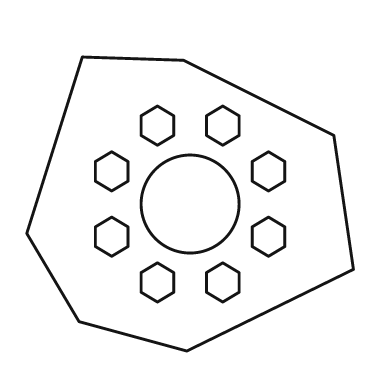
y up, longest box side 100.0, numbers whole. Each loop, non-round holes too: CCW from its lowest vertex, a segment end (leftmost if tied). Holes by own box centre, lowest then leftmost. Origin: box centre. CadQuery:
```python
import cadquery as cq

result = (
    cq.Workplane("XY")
    .moveTo(-1.0, -45.0)
    .lineTo(50.0, -20.0)
    .lineTo(44.0, 21.0)
    .lineTo(-2.0, 44.0)
    .lineTo(-33.0, 45.0)
    .lineTo(-50.0, -9.0)
    .lineTo(-34.0, -36.0)
    .close()
    .moveTo(-10.0, -30.0)
    .lineTo(-5.0, -27.0)
    .lineTo(-5.0, -21.0)
    .lineTo(-10.0, -18.0)
    .lineTo(-15.0, -21.0)
    .lineTo(-15.0, -27.0)
    .close()
    .moveTo(10.0, -30.0)
    .lineTo(15.0, -27.0)
    .lineTo(15.0, -21.0)
    .lineTo(10.0, -18.0)
    .lineTo(5.0, -21.0)
    .lineTo(5.0, -27.0)
    .close()
    .moveTo(-24.0, -16.0)
    .lineTo(-19.0, -13.0)
    .lineTo(-19.0, -7.0)
    .lineTo(-24.0, -4.0)
    .lineTo(-29.0, -7.0)
    .lineTo(-29.0, -13.0)
    .close()
    .moveTo(24.0, -16.0)
    .lineTo(29.0, -13.0)
    .lineTo(29.0, -7.0)
    .lineTo(24.0, -4.0)
    .lineTo(19.0, -7.0)
    .lineTo(19.0, -13.0)
    .close()
    .moveTo(0.0, 0.0)
    .circle(15.0)
    .moveTo(-24.0, 4.0)
    .lineTo(-19.0, 7.0)
    .lineTo(-19.0, 13.0)
    .lineTo(-24.0, 16.0)
    .lineTo(-29.0, 13.0)
    .lineTo(-29.0, 7.0)
    .close()
    .moveTo(24.0, 4.0)
    .lineTo(29.0, 7.0)
    .lineTo(29.0, 13.0)
    .lineTo(24.0, 16.0)
    .lineTo(19.0, 13.0)
    .lineTo(19.0, 7.0)
    .close()
    .moveTo(-10.0, 18.0)
    .lineTo(-5.0, 21.0)
    .lineTo(-5.0, 27.0)
    .lineTo(-10.0, 30.0)
    .lineTo(-15.0, 27.0)
    .lineTo(-15.0, 21.0)
    .close()
    .moveTo(10.0, 18.0)
    .lineTo(15.0, 21.0)
    .lineTo(15.0, 27.0)
    .lineTo(10.0, 30.0)
    .lineTo(5.0, 27.0)
    .lineTo(5.0, 21.0)
    .close()
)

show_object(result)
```